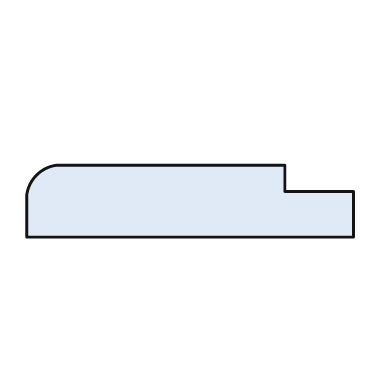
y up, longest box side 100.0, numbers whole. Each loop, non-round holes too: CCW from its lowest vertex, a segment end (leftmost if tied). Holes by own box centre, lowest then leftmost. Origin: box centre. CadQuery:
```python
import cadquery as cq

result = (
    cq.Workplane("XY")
    .moveTo(-50.0, -11.0)
    .lineTo(50.0, -11.0)
    .lineTo(50.0, 3.0)
    .lineTo(29.0, 3.0)
    .lineTo(29.0, 11.0)
    .lineTo(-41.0, 11.0)
    .threePointArc((-47.0, 8.0), (-50.0, 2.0))
    .close()
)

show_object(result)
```